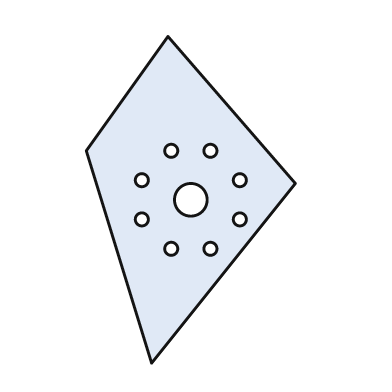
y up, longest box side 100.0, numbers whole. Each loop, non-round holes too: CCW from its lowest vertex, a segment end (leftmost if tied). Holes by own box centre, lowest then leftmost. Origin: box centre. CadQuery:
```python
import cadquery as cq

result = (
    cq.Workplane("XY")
    .moveTo(-12.0, -50.0)
    .lineTo(32.0, 5.0)
    .lineTo(-7.0, 50.0)
    .lineTo(-32.0, 15.0)
    .close()
    .moveTo(-6.0, -15.0)
    .circle(2.0)
    .moveTo(6.0, -15.0)
    .circle(2.0)
    .moveTo(-15.0, -6.0)
    .circle(2.0)
    .moveTo(15.0, -6.0)
    .circle(2.0)
    .moveTo(0.0, 0.0)
    .circle(5.0)
    .moveTo(-15.0, 6.0)
    .circle(2.0)
    .moveTo(15.0, 6.0)
    .circle(2.0)
    .moveTo(-6.0, 15.0)
    .circle(2.0)
    .moveTo(6.0, 15.0)
    .circle(2.0)
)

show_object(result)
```